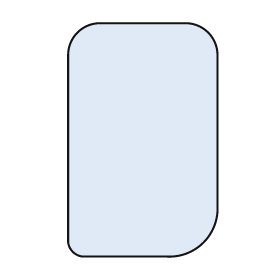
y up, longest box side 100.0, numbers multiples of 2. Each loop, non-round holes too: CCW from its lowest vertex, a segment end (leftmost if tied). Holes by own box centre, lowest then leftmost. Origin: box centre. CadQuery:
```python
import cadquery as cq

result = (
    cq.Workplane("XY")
    .moveTo(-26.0, -50.0)
    .lineTo(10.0, -50.0)
    .threePointArc((26.0, -44.0), (32.0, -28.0))
    .lineTo(32.0, 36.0)
    .threePointArc((28.0, 46.0), (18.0, 50.0))
    .lineTo(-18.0, 50.0)
    .threePointArc((-28.0, 46.0), (-32.0, 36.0))
    .lineTo(-32.0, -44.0)
    .threePointArc((-30.0, -48.0), (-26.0, -50.0))
    .close()
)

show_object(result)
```